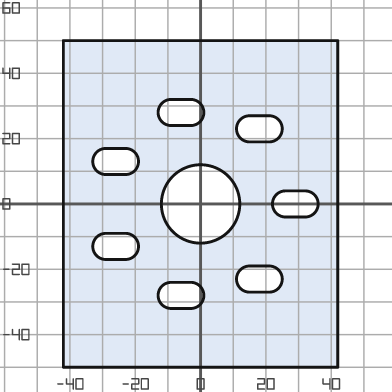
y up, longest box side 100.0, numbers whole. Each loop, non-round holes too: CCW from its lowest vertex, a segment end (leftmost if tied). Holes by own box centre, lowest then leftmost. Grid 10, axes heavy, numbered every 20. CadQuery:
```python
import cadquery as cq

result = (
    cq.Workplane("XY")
    .moveTo(-42.0, -50.0)
    .lineTo(42.0, -50.0)
    .lineTo(42.0, 50.0)
    .lineTo(-42.0, 50.0)
    .close()
    .moveTo(-9.0, -32.0)
    .lineTo(-3.0, -32.0)
    .threePointArc((1.0, -28.0), (-3.0, -24.0))
    .lineTo(-9.0, -24.0)
    .threePointArc((-13.0, -28.0), (-9.0, -32.0))
    .close()
    .moveTo(15.0, -27.0)
    .lineTo(21.0, -27.0)
    .threePointArc((25.0, -23.0), (21.0, -19.0))
    .lineTo(15.0, -19.0)
    .threePointArc((11.0, -23.0), (15.0, -27.0))
    .close()
    .moveTo(-29.0, -17.0)
    .lineTo(-23.0, -17.0)
    .threePointArc((-19.0, -13.0), (-23.0, -9.0))
    .lineTo(-29.0, -9.0)
    .threePointArc((-33.0, -13.0), (-29.0, -17.0))
    .close()
    .moveTo(0.0, 0.0)
    .circle(12.0)
    .moveTo(26.0, -4.0)
    .lineTo(32.0, -4.0)
    .threePointArc((36.0, 0.0), (32.0, 4.0))
    .lineTo(26.0, 4.0)
    .threePointArc((22.0, 0.0), (26.0, -4.0))
    .close()
    .moveTo(-29.0, 9.0)
    .lineTo(-23.0, 9.0)
    .threePointArc((-19.0, 13.0), (-23.0, 17.0))
    .lineTo(-29.0, 17.0)
    .threePointArc((-33.0, 13.0), (-29.0, 9.0))
    .close()
    .moveTo(15.0, 19.0)
    .lineTo(21.0, 19.0)
    .threePointArc((25.0, 23.0), (21.0, 27.0))
    .lineTo(15.0, 27.0)
    .threePointArc((11.0, 23.0), (15.0, 19.0))
    .close()
    .moveTo(-9.0, 24.0)
    .lineTo(-3.0, 24.0)
    .threePointArc((1.0, 28.0), (-3.0, 32.0))
    .lineTo(-9.0, 32.0)
    .threePointArc((-13.0, 28.0), (-9.0, 24.0))
    .close()
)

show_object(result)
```